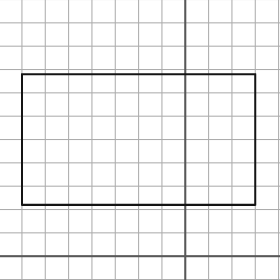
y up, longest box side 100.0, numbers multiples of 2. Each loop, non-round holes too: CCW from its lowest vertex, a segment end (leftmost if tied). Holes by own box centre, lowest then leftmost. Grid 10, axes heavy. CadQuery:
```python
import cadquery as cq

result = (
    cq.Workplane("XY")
    .moveTo(-70.0, 22.0)
    .lineTo(30.0, 22.0)
    .lineTo(30.0, 78.0)
    .lineTo(-70.0, 78.0)
    .close()
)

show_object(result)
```